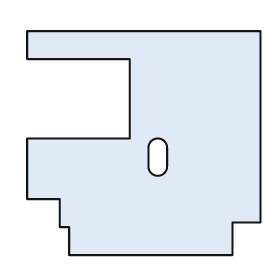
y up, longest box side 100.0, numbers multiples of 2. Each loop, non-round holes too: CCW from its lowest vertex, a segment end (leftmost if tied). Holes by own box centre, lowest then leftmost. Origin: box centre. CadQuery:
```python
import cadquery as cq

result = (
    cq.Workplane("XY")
    .moveTo(-32.0, -48.0)
    .lineTo(38.0, -48.0)
    .lineTo(38.0, -34.0)
    .lineTo(50.0, -34.0)
    .lineTo(50.0, 48.0)
    .lineTo(-50.0, 48.0)
    .lineTo(-50.0, 36.0)
    .lineTo(-6.0, 36.0)
    .lineTo(-6.0, 2.0)
    .lineTo(-50.0, 2.0)
    .lineTo(-50.0, -24.0)
    .lineTo(-36.0, -24.0)
    .lineTo(-36.0, -36.0)
    .lineTo(-32.0, -36.0)
    .close()
    .moveTo(2.0, -10.0)
    .threePointArc((6.0, -14.0), (10.0, -10.0))
    .lineTo(10.0, -2.0)
    .threePointArc((6.0, 2.0), (2.0, -2.0))
    .close()
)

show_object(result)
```